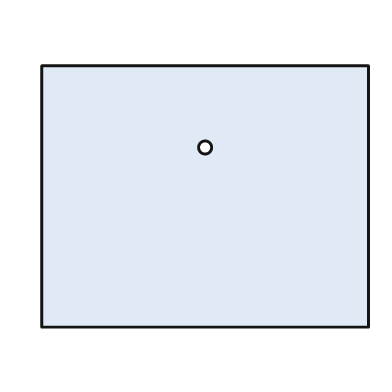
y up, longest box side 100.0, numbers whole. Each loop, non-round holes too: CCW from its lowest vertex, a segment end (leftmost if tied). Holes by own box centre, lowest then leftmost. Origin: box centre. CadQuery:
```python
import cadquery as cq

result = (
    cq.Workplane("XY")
    .moveTo(-50.0, -40.0)
    .lineTo(50.0, -40.0)
    .lineTo(50.0, 40.0)
    .lineTo(-50.0, 40.0)
    .close()
    .moveTo(0.0, 15.0)
    .circle(2.0)
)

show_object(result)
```